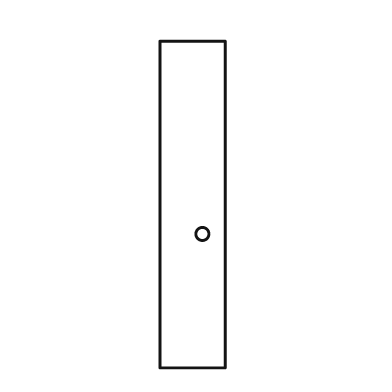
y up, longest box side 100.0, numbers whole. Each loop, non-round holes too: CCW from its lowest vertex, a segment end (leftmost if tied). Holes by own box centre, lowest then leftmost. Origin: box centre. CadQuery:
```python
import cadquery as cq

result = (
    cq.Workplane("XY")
    .moveTo(-10.0, -50.0)
    .lineTo(10.0, -50.0)
    .lineTo(10.0, 50.0)
    .lineTo(-10.0, 50.0)
    .close()
    .moveTo(3.0, -9.0)
    .circle(2.0)
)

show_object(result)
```